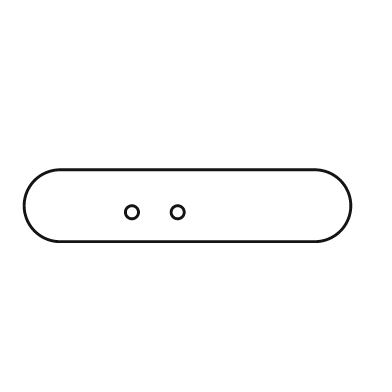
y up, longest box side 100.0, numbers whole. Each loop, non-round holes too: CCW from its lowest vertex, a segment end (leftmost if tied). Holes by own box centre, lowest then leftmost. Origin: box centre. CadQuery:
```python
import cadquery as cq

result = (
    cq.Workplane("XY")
    .moveTo(-39.0, -11.0)
    .lineTo(39.0, -11.0)
    .threePointArc((50.0, 0.0), (39.0, 11.0))
    .lineTo(-39.0, 11.0)
    .threePointArc((-50.0, 0.0), (-39.0, -11.0))
    .close()
    .moveTo(-17.0, -2.0)
    .circle(2.0)
    .moveTo(-3.0, -2.0)
    .circle(2.0)
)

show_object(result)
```